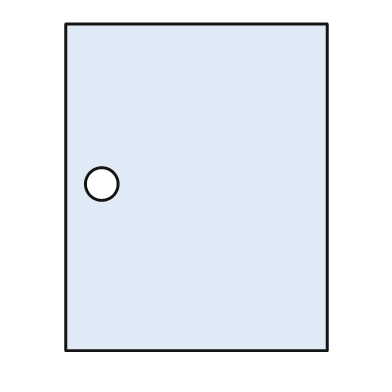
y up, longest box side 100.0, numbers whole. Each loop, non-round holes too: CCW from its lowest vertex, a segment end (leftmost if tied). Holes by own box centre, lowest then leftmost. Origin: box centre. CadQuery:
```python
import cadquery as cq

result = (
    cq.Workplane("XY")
    .moveTo(-40.0, -50.0)
    .lineTo(40.0, -50.0)
    .lineTo(40.0, 50.0)
    .lineTo(-40.0, 50.0)
    .close()
    .moveTo(-29.0, 1.0)
    .circle(5.0)
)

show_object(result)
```